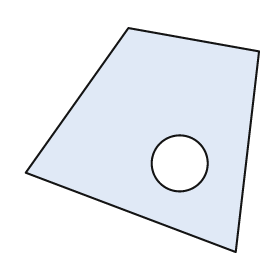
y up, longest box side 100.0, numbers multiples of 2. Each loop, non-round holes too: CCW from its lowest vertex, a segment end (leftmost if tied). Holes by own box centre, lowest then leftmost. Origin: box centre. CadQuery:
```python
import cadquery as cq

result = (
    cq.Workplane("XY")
    .moveTo(40.0, -48.0)
    .lineTo(50.0, 38.0)
    .lineTo(-6.0, 48.0)
    .lineTo(-50.0, -14.0)
    .close()
    .moveTo(16.0, -10.0)
    .circle(12.0)
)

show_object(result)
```